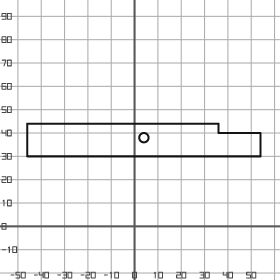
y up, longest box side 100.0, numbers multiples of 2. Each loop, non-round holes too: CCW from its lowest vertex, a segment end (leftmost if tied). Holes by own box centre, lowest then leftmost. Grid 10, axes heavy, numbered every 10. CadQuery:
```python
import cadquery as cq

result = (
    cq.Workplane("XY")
    .moveTo(-46.0, 30.0)
    .lineTo(54.0, 30.0)
    .lineTo(54.0, 40.0)
    .lineTo(36.0, 40.0)
    .lineTo(36.0, 44.0)
    .lineTo(-46.0, 44.0)
    .close()
    .moveTo(4.0, 38.0)
    .circle(2.0)
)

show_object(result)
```